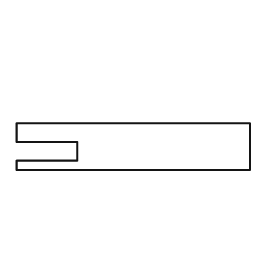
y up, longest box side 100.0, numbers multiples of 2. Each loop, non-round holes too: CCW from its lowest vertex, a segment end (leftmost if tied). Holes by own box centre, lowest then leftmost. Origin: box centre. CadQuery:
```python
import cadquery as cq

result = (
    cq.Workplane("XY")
    .moveTo(-50.0, -10.0)
    .lineTo(50.0, -10.0)
    .lineTo(50.0, 10.0)
    .lineTo(-50.0, 10.0)
    .lineTo(-50.0, 2.0)
    .lineTo(-24.0, 2.0)
    .lineTo(-24.0, -6.0)
    .lineTo(-50.0, -6.0)
    .close()
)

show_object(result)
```